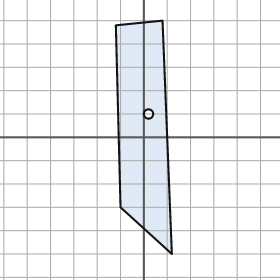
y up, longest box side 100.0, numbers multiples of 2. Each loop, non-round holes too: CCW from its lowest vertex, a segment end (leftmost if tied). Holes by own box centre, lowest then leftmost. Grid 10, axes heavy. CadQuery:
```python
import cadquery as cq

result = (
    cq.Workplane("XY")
    .moveTo(12.0, -50.0)
    .lineTo(8.0, 50.0)
    .lineTo(-12.0, 48.0)
    .lineTo(-10.0, -30.0)
    .close()
    .moveTo(2.0, 10.0)
    .circle(2.0)
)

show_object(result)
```